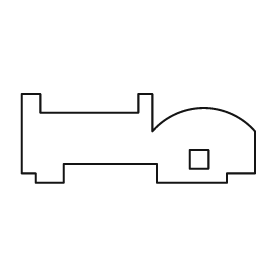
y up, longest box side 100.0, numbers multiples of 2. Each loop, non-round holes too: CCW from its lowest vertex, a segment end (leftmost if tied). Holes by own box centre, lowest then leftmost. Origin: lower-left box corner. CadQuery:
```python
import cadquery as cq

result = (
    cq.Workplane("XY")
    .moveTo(6.0, 0.0)
    .lineTo(18.0, 0.0)
    .lineTo(18.0, 8.0)
    .lineTo(58.0, 8.0)
    .lineTo(58.0, 0.0)
    .lineTo(88.0, 0.0)
    .lineTo(88.0, 4.0)
    .lineTo(100.0, 4.0)
    .lineTo(100.0, 22.0)
    .threePointArc((78.0, 32.0), (56.0, 22.0))
    .lineTo(56.0, 38.0)
    .lineTo(50.0, 38.0)
    .lineTo(50.0, 30.0)
    .lineTo(8.0, 30.0)
    .lineTo(8.0, 38.0)
    .lineTo(0.0, 38.0)
    .lineTo(0.0, 4.0)
    .lineTo(6.0, 4.0)
    .close()
    .moveTo(72.0, 6.0)
    .lineTo(80.0, 6.0)
    .lineTo(80.0, 14.0)
    .lineTo(72.0, 14.0)
    .close()
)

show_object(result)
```